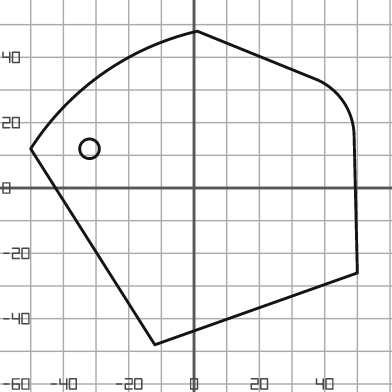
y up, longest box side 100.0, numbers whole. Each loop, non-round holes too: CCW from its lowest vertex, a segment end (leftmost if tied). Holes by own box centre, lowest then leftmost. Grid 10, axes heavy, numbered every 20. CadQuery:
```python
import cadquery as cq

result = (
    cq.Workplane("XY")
    .moveTo(-12.0, -48.0)
    .lineTo(50.0, -26.0)
    .lineTo(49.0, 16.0)
    .threePointArc((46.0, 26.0), (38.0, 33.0))
    .lineTo(1.0, 48.0)
    .threePointArc((-28.0, 35.0), (-50.0, 12.0))
    .close()
    .moveTo(-32.0, 12.0)
    .circle(3.0)
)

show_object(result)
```